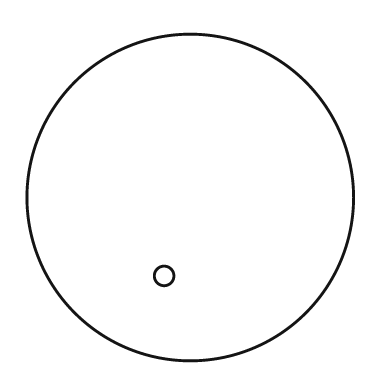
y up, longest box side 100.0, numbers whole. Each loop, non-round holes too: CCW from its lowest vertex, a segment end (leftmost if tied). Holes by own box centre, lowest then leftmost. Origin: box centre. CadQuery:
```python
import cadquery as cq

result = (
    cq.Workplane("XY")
    .moveTo(0.0, 0.0)
    .circle(50.0)
    .moveTo(-8.0, -24.0)
    .circle(3.0)
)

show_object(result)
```